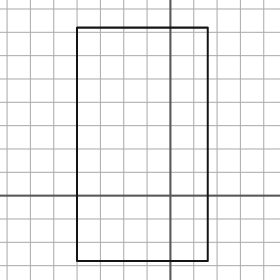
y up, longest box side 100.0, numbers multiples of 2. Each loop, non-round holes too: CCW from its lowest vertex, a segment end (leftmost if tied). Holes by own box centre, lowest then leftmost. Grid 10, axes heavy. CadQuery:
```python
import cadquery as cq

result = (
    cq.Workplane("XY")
    .moveTo(-40.0, -28.0)
    .lineTo(16.0, -28.0)
    .lineTo(16.0, 72.0)
    .lineTo(-40.0, 72.0)
    .close()
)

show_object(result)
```